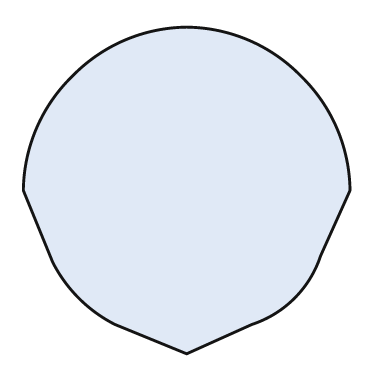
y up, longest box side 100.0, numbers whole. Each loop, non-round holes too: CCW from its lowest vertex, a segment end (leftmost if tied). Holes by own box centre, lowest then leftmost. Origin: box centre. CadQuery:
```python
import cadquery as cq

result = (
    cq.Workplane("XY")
    .moveTo(0.0, -50.0)
    .lineTo(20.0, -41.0)
    .threePointArc((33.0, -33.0), (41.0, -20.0))
    .lineTo(50.0, 0.0)
    .threePointArc((46.0, 19.0), (35.0, 35.0))
    .threePointArc((19.0, 46.0), (0.0, 50.0))
    .threePointArc((-19.0, 46.0), (-35.0, 35.0))
    .threePointArc((-46.0, 19.0), (-50.0, 0.0))
    .lineTo(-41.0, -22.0)
    .threePointArc((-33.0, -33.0), (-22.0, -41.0))
    .close()
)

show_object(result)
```